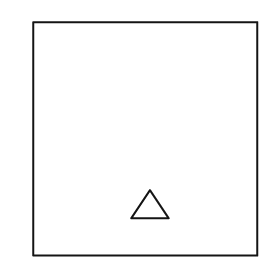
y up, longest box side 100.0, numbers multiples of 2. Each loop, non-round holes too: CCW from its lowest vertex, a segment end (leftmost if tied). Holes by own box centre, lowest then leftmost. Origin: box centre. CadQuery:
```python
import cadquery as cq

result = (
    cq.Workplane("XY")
    .moveTo(-48.0, -50.0)
    .lineTo(48.0, -50.0)
    .lineTo(48.0, 50.0)
    .lineTo(-48.0, 50.0)
    .close()
    .moveTo(-6.0, -34.0)
    .lineTo(10.0, -34.0)
    .lineTo(2.0, -22.0)
    .close()
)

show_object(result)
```